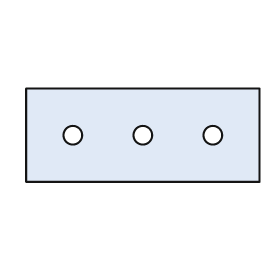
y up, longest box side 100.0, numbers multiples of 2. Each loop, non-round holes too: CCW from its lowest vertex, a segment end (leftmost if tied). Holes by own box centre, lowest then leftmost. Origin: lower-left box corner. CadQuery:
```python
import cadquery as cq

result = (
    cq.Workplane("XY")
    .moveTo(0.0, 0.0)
    .lineTo(100.0, 0.0)
    .lineTo(100.0, 40.0)
    .lineTo(0.0, 40.0)
    .close()
    .moveTo(20.0, 20.0)
    .circle(4.0)
    .moveTo(50.0, 20.0)
    .circle(4.0)
    .moveTo(80.0, 20.0)
    .circle(4.0)
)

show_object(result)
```